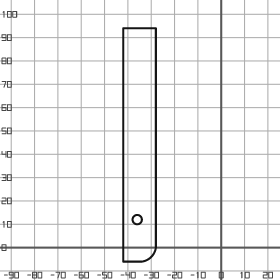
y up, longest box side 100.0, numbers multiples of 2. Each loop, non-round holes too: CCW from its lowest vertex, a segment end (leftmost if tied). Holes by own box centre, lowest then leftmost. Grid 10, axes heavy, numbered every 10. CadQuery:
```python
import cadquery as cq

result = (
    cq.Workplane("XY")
    .moveTo(-42.0, -6.0)
    .lineTo(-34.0, -6.0)
    .threePointArc((-30.0, -4.0), (-28.0, 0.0))
    .lineTo(-28.0, 94.0)
    .lineTo(-42.0, 94.0)
    .close()
    .moveTo(-36.0, 12.0)
    .circle(2.0)
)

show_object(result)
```